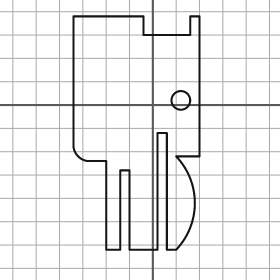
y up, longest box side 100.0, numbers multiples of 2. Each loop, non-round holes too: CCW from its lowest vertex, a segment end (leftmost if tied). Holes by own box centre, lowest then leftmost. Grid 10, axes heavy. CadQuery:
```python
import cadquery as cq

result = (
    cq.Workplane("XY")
    .moveTo(-20.0, -62.0)
    .lineTo(-14.0, -62.0)
    .lineTo(-14.0, -28.0)
    .lineTo(-10.0, -28.0)
    .lineTo(-10.0, -62.0)
    .lineTo(2.0, -62.0)
    .lineTo(2.0, -12.0)
    .lineTo(6.0, -12.0)
    .lineTo(6.0, -62.0)
    .lineTo(10.0, -62.0)
    .threePointArc((18.0, -42.0), (10.0, -22.0))
    .lineTo(20.0, -22.0)
    .lineTo(20.0, 38.0)
    .lineTo(16.0, 38.0)
    .lineTo(16.0, 30.0)
    .lineTo(-4.0, 30.0)
    .lineTo(-4.0, 38.0)
    .lineTo(-34.0, 38.0)
    .lineTo(-34.0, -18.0)
    .threePointArc((-32.0, -22.0), (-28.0, -24.0))
    .lineTo(-20.0, -24.0)
    .close()
    .moveTo(12.0, 2.0)
    .circle(4.0)
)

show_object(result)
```